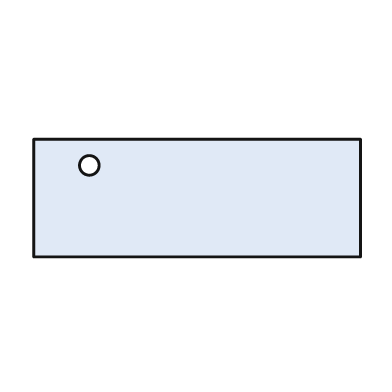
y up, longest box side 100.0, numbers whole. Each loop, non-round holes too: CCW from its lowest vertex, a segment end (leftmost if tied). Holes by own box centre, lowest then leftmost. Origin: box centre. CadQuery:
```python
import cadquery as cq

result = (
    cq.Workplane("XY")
    .moveTo(-50.0, -18.0)
    .lineTo(50.0, -18.0)
    .lineTo(50.0, 18.0)
    .lineTo(-50.0, 18.0)
    .close()
    .moveTo(-33.0, 10.0)
    .circle(3.0)
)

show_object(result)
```